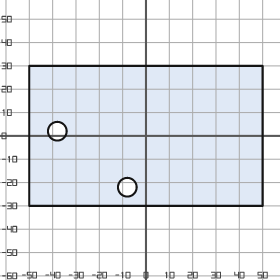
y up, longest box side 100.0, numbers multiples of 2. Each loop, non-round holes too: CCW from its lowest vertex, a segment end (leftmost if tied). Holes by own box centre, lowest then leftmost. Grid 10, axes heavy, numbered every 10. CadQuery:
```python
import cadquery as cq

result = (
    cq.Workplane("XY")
    .moveTo(-50.0, -30.0)
    .lineTo(50.0, -30.0)
    .lineTo(50.0, 30.0)
    .lineTo(-50.0, 30.0)
    .close()
    .moveTo(-8.0, -22.0)
    .circle(4.0)
    .moveTo(-38.0, 2.0)
    .circle(4.0)
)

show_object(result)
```